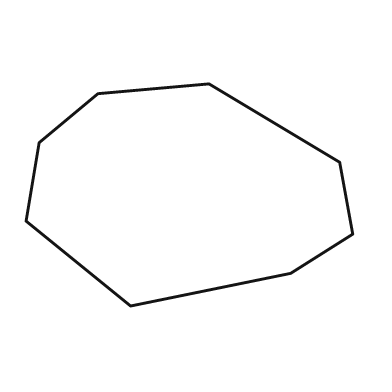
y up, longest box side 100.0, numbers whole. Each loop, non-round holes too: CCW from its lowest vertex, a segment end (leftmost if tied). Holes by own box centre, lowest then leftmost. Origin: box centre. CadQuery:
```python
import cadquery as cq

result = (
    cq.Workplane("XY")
    .moveTo(-18.0, -34.0)
    .lineTo(31.0, -24.0)
    .lineTo(50.0, -12.0)
    .lineTo(46.0, 10.0)
    .lineTo(6.0, 34.0)
    .lineTo(-28.0, 31.0)
    .lineTo(-46.0, 16.0)
    .lineTo(-50.0, -8.0)
    .close()
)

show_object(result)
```